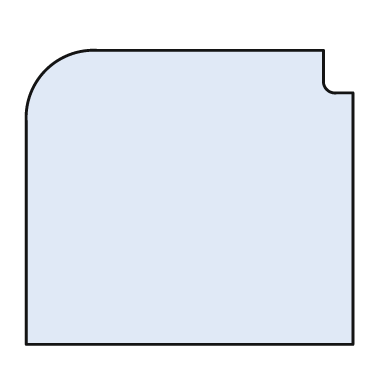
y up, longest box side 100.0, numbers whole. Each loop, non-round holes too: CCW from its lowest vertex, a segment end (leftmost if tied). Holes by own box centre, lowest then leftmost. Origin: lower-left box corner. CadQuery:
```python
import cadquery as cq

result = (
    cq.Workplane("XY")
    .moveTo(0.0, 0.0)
    .lineTo(100.0, 0.0)
    .lineTo(100.0, 77.0)
    .lineTo(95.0, 77.0)
    .threePointArc((92.0, 78.0), (91.0, 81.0))
    .lineTo(91.0, 90.0)
    .lineTo(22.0, 90.0)
    .threePointArc((6.0, 84.0), (0.0, 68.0))
    .close()
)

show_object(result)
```